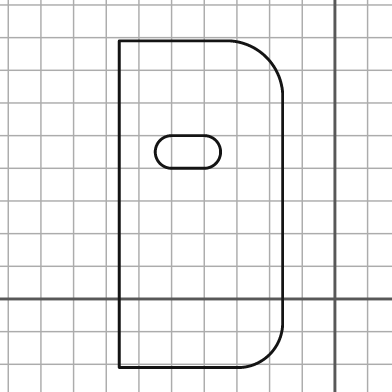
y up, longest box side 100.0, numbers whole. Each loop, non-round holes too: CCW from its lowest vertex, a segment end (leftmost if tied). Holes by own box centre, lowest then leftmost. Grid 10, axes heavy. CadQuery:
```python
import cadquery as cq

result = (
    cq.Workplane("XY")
    .moveTo(-66.0, -21.0)
    .lineTo(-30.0, -21.0)
    .threePointArc((-20.0, -17.0), (-16.0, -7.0))
    .lineTo(-16.0, 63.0)
    .threePointArc((-21.0, 74.0), (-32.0, 79.0))
    .lineTo(-66.0, 79.0)
    .close()
    .moveTo(-50.0, 40.0)
    .lineTo(-40.0, 40.0)
    .threePointArc((-35.0, 45.0), (-40.0, 50.0))
    .lineTo(-50.0, 50.0)
    .threePointArc((-55.0, 45.0), (-50.0, 40.0))
    .close()
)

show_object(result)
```